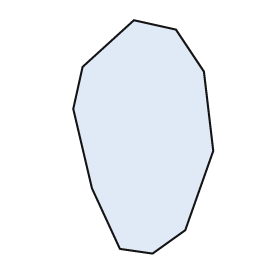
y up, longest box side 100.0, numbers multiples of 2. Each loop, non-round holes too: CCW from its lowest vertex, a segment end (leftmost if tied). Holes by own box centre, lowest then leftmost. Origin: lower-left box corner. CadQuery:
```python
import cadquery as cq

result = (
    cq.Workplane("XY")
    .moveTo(34.0, 0.0)
    .lineTo(48.0, 10.0)
    .lineTo(60.0, 44.0)
    .lineTo(56.0, 78.0)
    .lineTo(44.0, 96.0)
    .lineTo(26.0, 100.0)
    .lineTo(4.0, 80.0)
    .lineTo(0.0, 62.0)
    .lineTo(8.0, 28.0)
    .lineTo(20.0, 2.0)
    .close()
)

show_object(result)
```